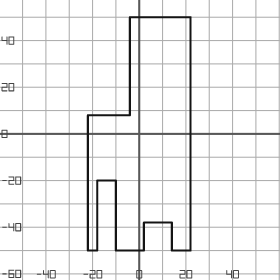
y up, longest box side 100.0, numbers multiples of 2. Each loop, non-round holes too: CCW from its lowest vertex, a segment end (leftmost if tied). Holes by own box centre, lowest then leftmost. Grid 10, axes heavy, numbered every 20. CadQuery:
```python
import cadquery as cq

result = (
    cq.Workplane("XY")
    .moveTo(-22.0, -50.0)
    .lineTo(-18.0, -50.0)
    .lineTo(-18.0, -20.0)
    .lineTo(-10.0, -20.0)
    .lineTo(-10.0, -50.0)
    .lineTo(2.0, -50.0)
    .lineTo(2.0, -38.0)
    .lineTo(14.0, -38.0)
    .lineTo(14.0, -50.0)
    .lineTo(22.0, -50.0)
    .lineTo(22.0, 50.0)
    .lineTo(-4.0, 50.0)
    .lineTo(-4.0, 8.0)
    .lineTo(-22.0, 8.0)
    .close()
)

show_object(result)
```